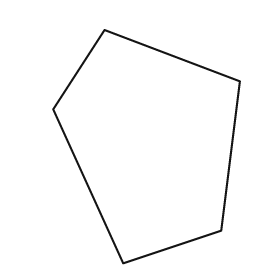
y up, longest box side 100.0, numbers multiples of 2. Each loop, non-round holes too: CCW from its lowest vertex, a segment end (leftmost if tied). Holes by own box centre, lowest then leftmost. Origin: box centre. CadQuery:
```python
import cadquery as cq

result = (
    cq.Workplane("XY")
    .moveTo(-10.0, -50.0)
    .lineTo(32.0, -36.0)
    .lineTo(40.0, 28.0)
    .lineTo(-18.0, 50.0)
    .lineTo(-40.0, 16.0)
    .close()
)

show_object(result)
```